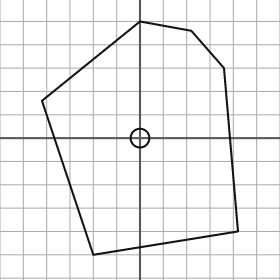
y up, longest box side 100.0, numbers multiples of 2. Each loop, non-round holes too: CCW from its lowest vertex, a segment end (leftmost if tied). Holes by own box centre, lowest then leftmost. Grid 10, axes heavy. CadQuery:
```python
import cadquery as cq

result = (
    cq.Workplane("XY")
    .moveTo(-20.0, -50.0)
    .lineTo(42.0, -40.0)
    .lineTo(36.0, 30.0)
    .lineTo(22.0, 46.0)
    .lineTo(0.0, 50.0)
    .lineTo(-42.0, 16.0)
    .close()
    .moveTo(0.0, 0.0)
    .circle(4.0)
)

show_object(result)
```